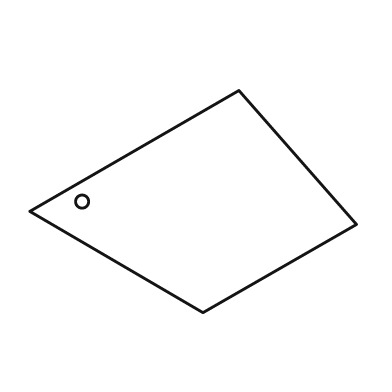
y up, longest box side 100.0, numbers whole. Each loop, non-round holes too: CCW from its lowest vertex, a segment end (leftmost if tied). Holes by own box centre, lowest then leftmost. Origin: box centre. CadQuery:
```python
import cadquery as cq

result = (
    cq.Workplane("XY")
    .moveTo(3.0, -34.0)
    .lineTo(50.0, -7.0)
    .lineTo(14.0, 34.0)
    .lineTo(-50.0, -3.0)
    .close()
    .moveTo(-34.0, 0.0)
    .circle(2.0)
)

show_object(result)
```